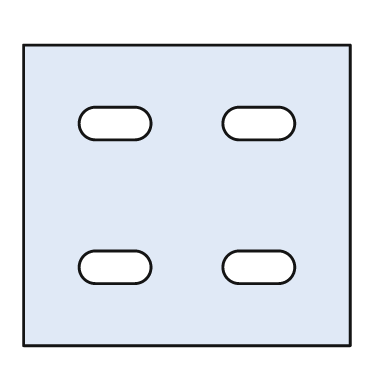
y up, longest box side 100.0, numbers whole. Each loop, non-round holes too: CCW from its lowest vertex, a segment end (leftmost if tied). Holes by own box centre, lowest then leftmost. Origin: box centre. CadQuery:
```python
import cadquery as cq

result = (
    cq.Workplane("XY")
    .moveTo(-50.0, -46.0)
    .lineTo(50.0, -46.0)
    .lineTo(50.0, 46.0)
    .lineTo(-50.0, 46.0)
    .close()
    .moveTo(-28.0, -27.0)
    .lineTo(-16.0, -27.0)
    .threePointArc((-11.0, -22.0), (-16.0, -17.0))
    .lineTo(-28.0, -17.0)
    .threePointArc((-33.0, -22.0), (-28.0, -27.0))
    .close()
    .moveTo(16.0, -27.0)
    .lineTo(28.0, -27.0)
    .threePointArc((33.0, -22.0), (28.0, -17.0))
    .lineTo(16.0, -17.0)
    .threePointArc((11.0, -22.0), (16.0, -27.0))
    .close()
    .moveTo(-28.0, 17.0)
    .lineTo(-16.0, 17.0)
    .threePointArc((-11.0, 22.0), (-16.0, 27.0))
    .lineTo(-28.0, 27.0)
    .threePointArc((-33.0, 22.0), (-28.0, 17.0))
    .close()
    .moveTo(16.0, 17.0)
    .lineTo(28.0, 17.0)
    .threePointArc((33.0, 22.0), (28.0, 27.0))
    .lineTo(16.0, 27.0)
    .threePointArc((11.0, 22.0), (16.0, 17.0))
    .close()
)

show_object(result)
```